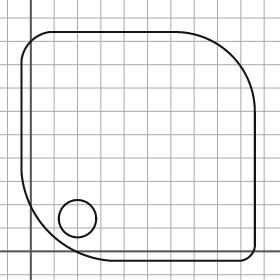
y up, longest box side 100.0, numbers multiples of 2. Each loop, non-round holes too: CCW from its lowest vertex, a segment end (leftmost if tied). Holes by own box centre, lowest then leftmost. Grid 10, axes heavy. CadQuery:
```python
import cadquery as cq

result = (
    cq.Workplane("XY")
    .moveTo(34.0, -4.0)
    .lineTo(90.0, -4.0)
    .threePointArc((94.0, -2.0), (96.0, 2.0))
    .lineTo(96.0, 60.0)
    .threePointArc((86.0, 84.0), (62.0, 94.0))
    .lineTo(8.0, 94.0)
    .threePointArc((0.0, 90.0), (-4.0, 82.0))
    .lineTo(-4.0, 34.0)
    .threePointArc((8.0, 8.0), (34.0, -4.0))
    .close()
    .moveTo(20.0, 14.0)
    .circle(8.0)
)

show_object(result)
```